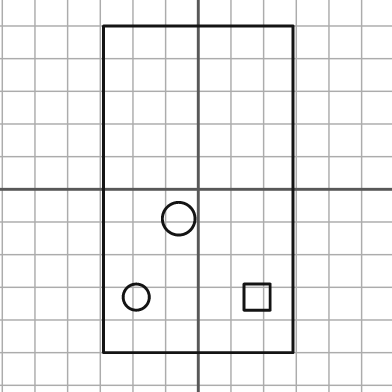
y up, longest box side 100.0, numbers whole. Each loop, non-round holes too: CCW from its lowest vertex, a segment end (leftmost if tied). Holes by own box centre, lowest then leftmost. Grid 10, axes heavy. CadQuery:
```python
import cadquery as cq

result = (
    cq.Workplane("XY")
    .moveTo(-29.0, -50.0)
    .lineTo(29.0, -50.0)
    .lineTo(29.0, 50.0)
    .lineTo(-29.0, 50.0)
    .close()
    .moveTo(-19.0, -33.0)
    .circle(4.0)
    .moveTo(14.0, -37.0)
    .lineTo(22.0, -37.0)
    .lineTo(22.0, -29.0)
    .lineTo(14.0, -29.0)
    .close()
    .moveTo(-6.0, -9.0)
    .circle(5.0)
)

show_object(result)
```